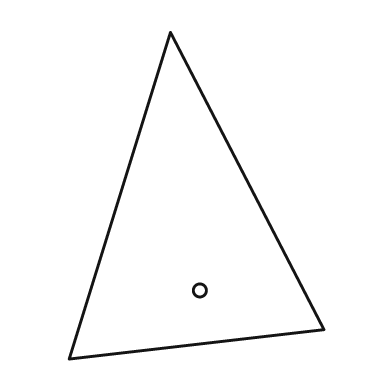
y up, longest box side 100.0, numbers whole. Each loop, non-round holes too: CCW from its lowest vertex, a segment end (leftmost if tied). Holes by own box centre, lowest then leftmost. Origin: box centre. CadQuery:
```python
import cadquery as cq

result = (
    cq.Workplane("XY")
    .moveTo(-39.0, -50.0)
    .lineTo(39.0, -41.0)
    .lineTo(-8.0, 50.0)
    .close()
    .moveTo(1.0, -29.0)
    .circle(2.0)
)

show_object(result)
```